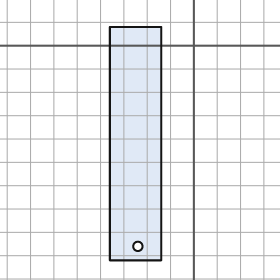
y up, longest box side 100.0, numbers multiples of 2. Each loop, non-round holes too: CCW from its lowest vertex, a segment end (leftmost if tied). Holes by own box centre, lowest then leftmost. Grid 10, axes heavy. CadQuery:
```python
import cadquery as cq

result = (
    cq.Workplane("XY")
    .moveTo(-36.0, -92.0)
    .lineTo(-14.0, -92.0)
    .lineTo(-14.0, 8.0)
    .lineTo(-36.0, 8.0)
    .close()
    .moveTo(-24.0, -86.0)
    .circle(2.0)
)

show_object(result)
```